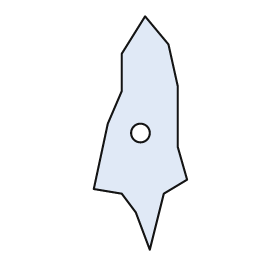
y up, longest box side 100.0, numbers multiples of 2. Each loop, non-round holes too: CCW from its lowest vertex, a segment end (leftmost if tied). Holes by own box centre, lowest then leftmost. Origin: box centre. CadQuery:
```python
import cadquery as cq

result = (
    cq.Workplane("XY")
    .moveTo(4.0, -50.0)
    .lineTo(10.0, -26.0)
    .lineTo(20.0, -20.0)
    .lineTo(16.0, -6.0)
    .lineTo(16.0, 20.0)
    .lineTo(12.0, 38.0)
    .lineTo(2.0, 50.0)
    .lineTo(-8.0, 34.0)
    .lineTo(-8.0, 18.0)
    .lineTo(-14.0, 4.0)
    .lineTo(-20.0, -24.0)
    .lineTo(-8.0, -26.0)
    .lineTo(-2.0, -34.0)
    .close()
    .moveTo(0.0, 0.0)
    .circle(4.0)
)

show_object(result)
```